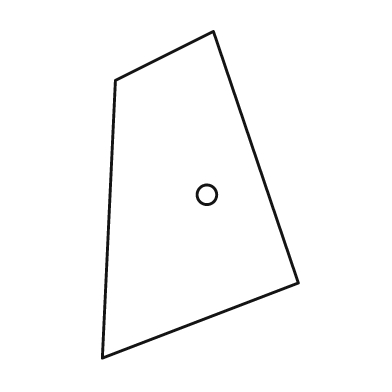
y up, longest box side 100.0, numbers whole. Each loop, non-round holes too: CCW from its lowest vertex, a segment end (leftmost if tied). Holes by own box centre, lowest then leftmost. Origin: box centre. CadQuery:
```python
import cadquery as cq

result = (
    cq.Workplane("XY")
    .moveTo(-30.0, -50.0)
    .lineTo(30.0, -27.0)
    .lineTo(4.0, 50.0)
    .lineTo(-26.0, 35.0)
    .close()
    .moveTo(2.0, 0.0)
    .circle(3.0)
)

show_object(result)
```